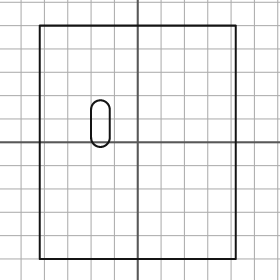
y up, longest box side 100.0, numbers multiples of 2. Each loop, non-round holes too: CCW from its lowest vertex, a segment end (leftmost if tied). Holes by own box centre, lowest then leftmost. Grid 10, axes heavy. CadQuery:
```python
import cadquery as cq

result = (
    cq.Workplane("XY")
    .moveTo(-42.0, -50.0)
    .lineTo(42.0, -50.0)
    .lineTo(42.0, 50.0)
    .lineTo(-42.0, 50.0)
    .close()
    .moveTo(-20.0, 2.0)
    .threePointArc((-16.0, -2.0), (-12.0, 2.0))
    .lineTo(-12.0, 14.0)
    .threePointArc((-16.0, 18.0), (-20.0, 14.0))
    .close()
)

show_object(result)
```